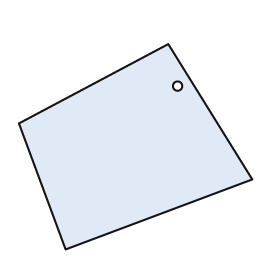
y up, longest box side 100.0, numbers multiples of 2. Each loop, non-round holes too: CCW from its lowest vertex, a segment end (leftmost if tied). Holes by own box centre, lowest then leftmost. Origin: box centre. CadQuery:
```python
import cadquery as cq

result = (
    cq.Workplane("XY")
    .moveTo(-30.0, -44.0)
    .lineTo(50.0, -14.0)
    .lineTo(14.0, 44.0)
    .lineTo(-50.0, 10.0)
    .close()
    .moveTo(18.0, 26.0)
    .circle(2.0)
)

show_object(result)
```